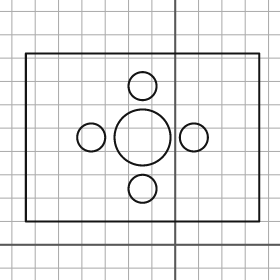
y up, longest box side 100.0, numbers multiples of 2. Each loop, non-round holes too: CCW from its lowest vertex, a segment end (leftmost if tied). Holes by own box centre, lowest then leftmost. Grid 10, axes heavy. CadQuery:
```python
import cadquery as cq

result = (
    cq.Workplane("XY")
    .moveTo(-64.0, 10.0)
    .lineTo(36.0, 10.0)
    .lineTo(36.0, 82.0)
    .lineTo(-64.0, 82.0)
    .close()
    .moveTo(-14.0, 24.0)
    .circle(6.0)
    .moveTo(-36.0, 46.0)
    .circle(6.0)
    .moveTo(-14.0, 46.0)
    .circle(12.0)
    .moveTo(8.0, 46.0)
    .circle(6.0)
    .moveTo(-14.0, 68.0)
    .circle(6.0)
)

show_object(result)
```